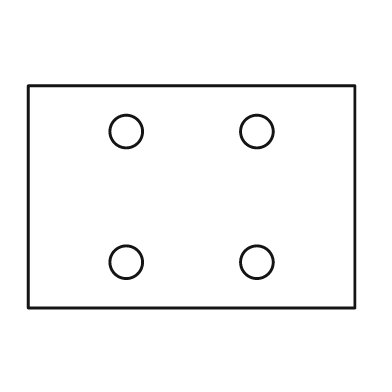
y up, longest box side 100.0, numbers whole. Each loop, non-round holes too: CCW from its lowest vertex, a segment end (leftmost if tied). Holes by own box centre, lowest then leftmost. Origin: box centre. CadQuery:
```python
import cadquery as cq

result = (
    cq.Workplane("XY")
    .moveTo(-50.0, -34.0)
    .lineTo(50.0, -34.0)
    .lineTo(50.0, 34.0)
    .lineTo(-50.0, 34.0)
    .close()
    .moveTo(-20.0, -20.0)
    .circle(5.0)
    .moveTo(20.0, -20.0)
    .circle(5.0)
    .moveTo(-20.0, 20.0)
    .circle(5.0)
    .moveTo(20.0, 20.0)
    .circle(5.0)
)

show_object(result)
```